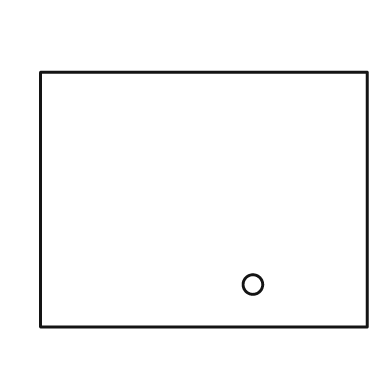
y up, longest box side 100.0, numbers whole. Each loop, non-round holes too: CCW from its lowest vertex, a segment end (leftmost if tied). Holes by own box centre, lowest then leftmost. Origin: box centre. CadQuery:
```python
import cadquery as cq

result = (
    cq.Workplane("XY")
    .moveTo(-50.0, -39.0)
    .lineTo(50.0, -39.0)
    .lineTo(50.0, 39.0)
    .lineTo(-50.0, 39.0)
    .close()
    .moveTo(15.0, -26.0)
    .circle(3.0)
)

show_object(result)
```